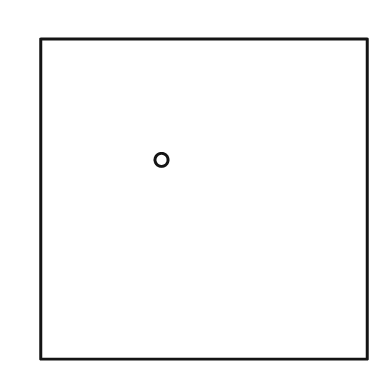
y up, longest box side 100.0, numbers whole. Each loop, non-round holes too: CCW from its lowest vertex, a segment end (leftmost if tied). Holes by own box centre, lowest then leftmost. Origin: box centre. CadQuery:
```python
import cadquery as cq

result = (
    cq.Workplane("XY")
    .moveTo(-50.0, -49.0)
    .lineTo(50.0, -49.0)
    .lineTo(50.0, 49.0)
    .lineTo(-50.0, 49.0)
    .close()
    .moveTo(-13.0, 12.0)
    .circle(2.0)
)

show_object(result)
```